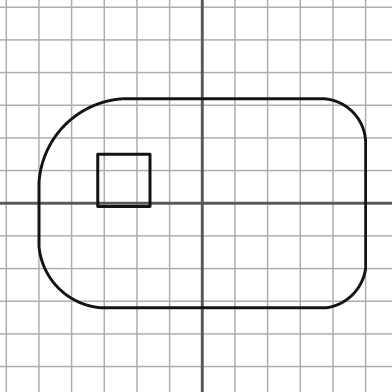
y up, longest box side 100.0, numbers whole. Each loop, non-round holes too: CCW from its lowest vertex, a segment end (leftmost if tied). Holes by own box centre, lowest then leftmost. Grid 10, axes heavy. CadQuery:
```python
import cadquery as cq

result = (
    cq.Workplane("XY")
    .moveTo(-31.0, -32.0)
    .lineTo(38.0, -32.0)
    .threePointArc((46.0, -28.0), (50.0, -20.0))
    .lineTo(50.0, 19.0)
    .threePointArc((46.0, 28.0), (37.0, 32.0))
    .lineTo(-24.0, 32.0)
    .threePointArc((-42.0, 24.0), (-50.0, 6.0))
    .lineTo(-50.0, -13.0)
    .threePointArc((-44.0, -26.0), (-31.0, -32.0))
    .close()
    .moveTo(-32.0, -1.0)
    .lineTo(-16.0, -1.0)
    .lineTo(-16.0, 15.0)
    .lineTo(-32.0, 15.0)
    .close()
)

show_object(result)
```